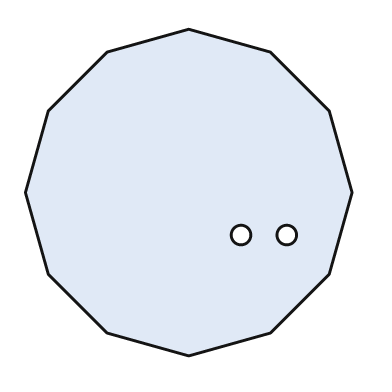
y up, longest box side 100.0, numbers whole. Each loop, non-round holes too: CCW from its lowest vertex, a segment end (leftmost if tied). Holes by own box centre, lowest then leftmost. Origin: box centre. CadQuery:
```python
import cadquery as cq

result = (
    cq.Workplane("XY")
    .moveTo(0.0, -50.0)
    .lineTo(25.0, -43.0)
    .lineTo(43.0, -25.0)
    .lineTo(50.0, 0.0)
    .lineTo(43.0, 25.0)
    .lineTo(25.0, 43.0)
    .lineTo(0.0, 50.0)
    .lineTo(-25.0, 43.0)
    .lineTo(-43.0, 25.0)
    .lineTo(-50.0, 0.0)
    .lineTo(-43.0, -25.0)
    .lineTo(-25.0, -43.0)
    .close()
    .moveTo(16.0, -13.0)
    .circle(3.0)
    .moveTo(30.0, -13.0)
    .circle(3.0)
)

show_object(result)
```